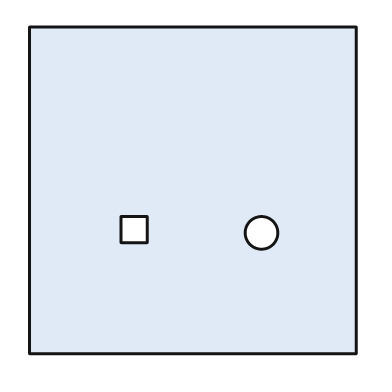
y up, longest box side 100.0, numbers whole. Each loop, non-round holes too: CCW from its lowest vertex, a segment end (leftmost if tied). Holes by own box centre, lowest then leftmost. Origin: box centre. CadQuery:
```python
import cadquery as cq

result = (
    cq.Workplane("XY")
    .moveTo(-50.0, -50.0)
    .lineTo(50.0, -50.0)
    .lineTo(50.0, 50.0)
    .lineTo(-50.0, 50.0)
    .close()
    .moveTo(21.0, -13.0)
    .circle(5.0)
    .moveTo(-22.0, -16.0)
    .lineTo(-14.0, -16.0)
    .lineTo(-14.0, -8.0)
    .lineTo(-22.0, -8.0)
    .close()
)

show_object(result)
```